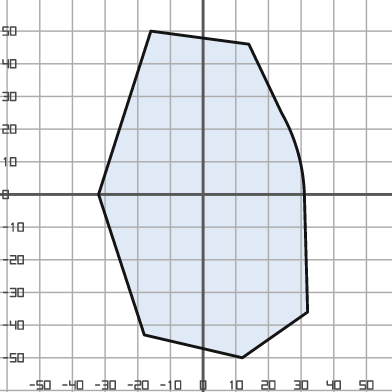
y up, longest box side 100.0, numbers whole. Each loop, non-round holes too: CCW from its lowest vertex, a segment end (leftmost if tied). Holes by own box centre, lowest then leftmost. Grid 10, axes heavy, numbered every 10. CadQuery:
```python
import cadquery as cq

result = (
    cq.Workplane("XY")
    .moveTo(12.0, -50.0)
    .lineTo(32.0, -36.0)
    .lineTo(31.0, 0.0)
    .threePointArc((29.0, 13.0), (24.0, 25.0))
    .lineTo(14.0, 46.0)
    .lineTo(-16.0, 50.0)
    .lineTo(-32.0, 0.0)
    .lineTo(-18.0, -43.0)
    .close()
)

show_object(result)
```